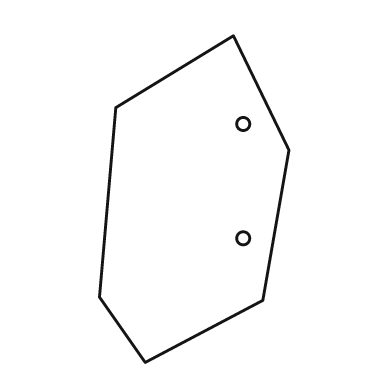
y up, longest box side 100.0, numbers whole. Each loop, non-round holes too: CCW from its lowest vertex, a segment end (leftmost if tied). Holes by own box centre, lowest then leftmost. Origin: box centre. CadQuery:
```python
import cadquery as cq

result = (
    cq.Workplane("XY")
    .moveTo(-15.0, -50.0)
    .lineTo(21.0, -31.0)
    .lineTo(29.0, 15.0)
    .lineTo(12.0, 50.0)
    .lineTo(-24.0, 28.0)
    .lineTo(-29.0, -30.0)
    .close()
    .moveTo(15.0, -12.0)
    .circle(2.0)
    .moveTo(15.0, 23.0)
    .circle(2.0)
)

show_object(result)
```